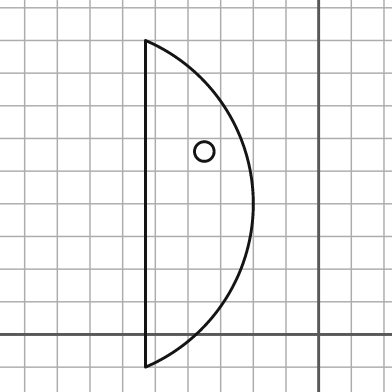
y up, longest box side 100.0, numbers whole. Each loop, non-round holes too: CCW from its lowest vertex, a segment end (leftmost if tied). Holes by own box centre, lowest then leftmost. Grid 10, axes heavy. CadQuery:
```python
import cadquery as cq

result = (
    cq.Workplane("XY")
    .moveTo(-53.0, -10.0)
    .threePointArc((-20.0, 40.0), (-53.0, 90.0))
    .close()
    .moveTo(-35.0, 56.0)
    .circle(3.0)
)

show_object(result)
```